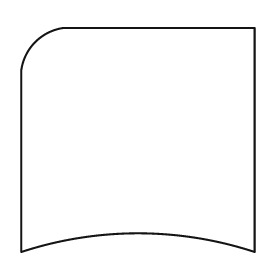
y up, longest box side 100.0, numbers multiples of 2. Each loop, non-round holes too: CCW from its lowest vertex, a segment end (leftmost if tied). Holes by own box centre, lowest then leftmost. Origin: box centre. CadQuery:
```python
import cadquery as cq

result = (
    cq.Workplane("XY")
    .moveTo(-50.0, -48.0)
    .threePointArc((0.0, -40.0), (50.0, -48.0))
    .lineTo(50.0, 48.0)
    .lineTo(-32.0, 48.0)
    .threePointArc((-44.0, 42.0), (-50.0, 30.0))
    .close()
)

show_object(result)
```